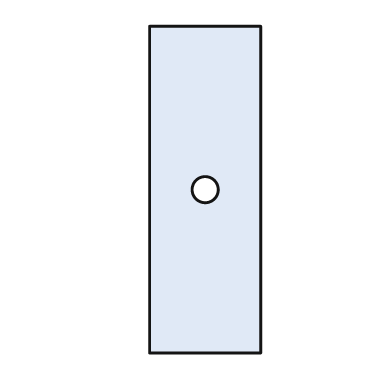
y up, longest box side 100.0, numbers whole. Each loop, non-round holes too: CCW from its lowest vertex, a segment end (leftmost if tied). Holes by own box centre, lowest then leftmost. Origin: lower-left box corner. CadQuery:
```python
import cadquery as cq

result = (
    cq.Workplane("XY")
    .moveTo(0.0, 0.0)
    .lineTo(34.0, 0.0)
    .lineTo(34.0, 100.0)
    .lineTo(0.0, 100.0)
    .close()
    .moveTo(17.0, 50.0)
    .circle(4.0)
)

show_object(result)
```